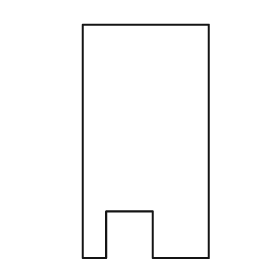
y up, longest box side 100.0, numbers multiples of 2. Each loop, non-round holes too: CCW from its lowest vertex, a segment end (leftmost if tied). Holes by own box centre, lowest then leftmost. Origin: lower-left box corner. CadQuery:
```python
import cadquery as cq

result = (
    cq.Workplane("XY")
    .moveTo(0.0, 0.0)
    .lineTo(10.0, 0.0)
    .lineTo(10.0, 20.0)
    .lineTo(30.0, 20.0)
    .lineTo(30.0, 0.0)
    .lineTo(54.0, 0.0)
    .lineTo(54.0, 100.0)
    .lineTo(0.0, 100.0)
    .close()
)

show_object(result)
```